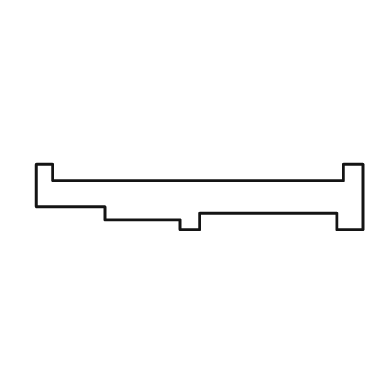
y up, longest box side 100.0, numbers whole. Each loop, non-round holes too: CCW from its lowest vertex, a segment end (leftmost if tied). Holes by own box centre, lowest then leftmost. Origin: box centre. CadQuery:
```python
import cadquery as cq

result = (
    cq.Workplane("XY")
    .moveTo(-6.0, -10.0)
    .lineTo(0.0, -10.0)
    .lineTo(0.0, -5.0)
    .lineTo(42.0, -5.0)
    .lineTo(42.0, -10.0)
    .lineTo(50.0, -10.0)
    .lineTo(50.0, 10.0)
    .lineTo(44.0, 10.0)
    .lineTo(44.0, 5.0)
    .lineTo(-45.0, 5.0)
    .lineTo(-45.0, 10.0)
    .lineTo(-50.0, 10.0)
    .lineTo(-50.0, -3.0)
    .lineTo(-29.0, -3.0)
    .lineTo(-29.0, -7.0)
    .lineTo(-6.0, -7.0)
    .close()
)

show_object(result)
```